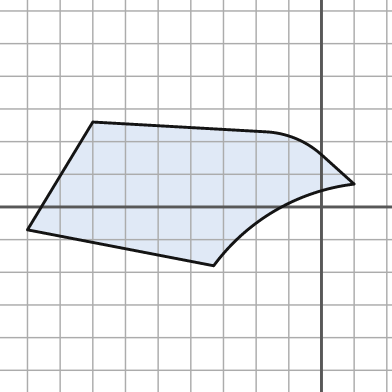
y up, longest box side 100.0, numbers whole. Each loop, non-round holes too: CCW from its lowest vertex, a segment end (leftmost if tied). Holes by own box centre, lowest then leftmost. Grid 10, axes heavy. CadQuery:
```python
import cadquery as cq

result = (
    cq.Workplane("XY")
    .moveTo(-33.0, -18.0)
    .threePointArc((-14.0, -1.0), (10.0, 7.0))
    .lineTo(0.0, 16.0)
    .threePointArc((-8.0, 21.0), (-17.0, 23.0))
    .lineTo(-70.0, 26.0)
    .lineTo(-90.0, -7.0)
    .close()
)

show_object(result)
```